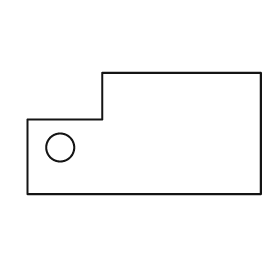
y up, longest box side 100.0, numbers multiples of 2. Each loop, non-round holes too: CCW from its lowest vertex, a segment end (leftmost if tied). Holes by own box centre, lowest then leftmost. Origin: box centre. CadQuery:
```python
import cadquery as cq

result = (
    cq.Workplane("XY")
    .moveTo(-50.0, -26.0)
    .lineTo(50.0, -26.0)
    .lineTo(50.0, 26.0)
    .lineTo(-18.0, 26.0)
    .lineTo(-18.0, 6.0)
    .lineTo(-50.0, 6.0)
    .close()
    .moveTo(-36.0, -6.0)
    .circle(6.0)
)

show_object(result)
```